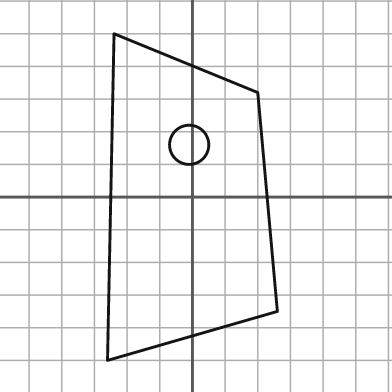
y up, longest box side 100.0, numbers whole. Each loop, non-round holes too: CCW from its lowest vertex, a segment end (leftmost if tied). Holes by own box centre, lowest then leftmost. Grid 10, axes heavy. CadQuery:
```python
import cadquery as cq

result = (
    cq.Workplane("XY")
    .moveTo(-26.0, -50.0)
    .lineTo(26.0, -35.0)
    .lineTo(20.0, 32.0)
    .lineTo(-24.0, 50.0)
    .close()
    .moveTo(-1.0, 16.0)
    .circle(6.0)
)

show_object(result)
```